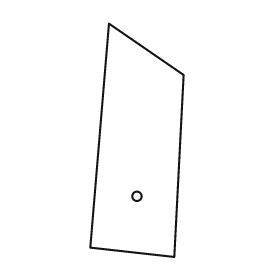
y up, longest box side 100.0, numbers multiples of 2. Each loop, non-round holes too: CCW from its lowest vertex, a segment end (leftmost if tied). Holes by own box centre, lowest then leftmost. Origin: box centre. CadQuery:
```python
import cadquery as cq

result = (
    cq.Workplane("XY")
    .moveTo(16.0, -50.0)
    .lineTo(20.0, 28.0)
    .lineTo(-12.0, 50.0)
    .lineTo(-20.0, -46.0)
    .close()
    .moveTo(0.0, -24.0)
    .circle(2.0)
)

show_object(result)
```